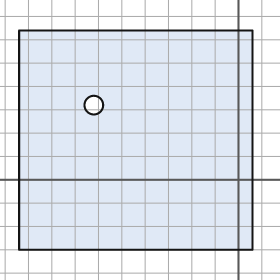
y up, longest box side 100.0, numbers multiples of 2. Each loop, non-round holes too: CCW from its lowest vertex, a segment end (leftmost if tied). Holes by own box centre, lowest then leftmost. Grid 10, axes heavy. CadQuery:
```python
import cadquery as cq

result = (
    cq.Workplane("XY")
    .moveTo(-94.0, -30.0)
    .lineTo(6.0, -30.0)
    .lineTo(6.0, 64.0)
    .lineTo(-94.0, 64.0)
    .close()
    .moveTo(-62.0, 32.0)
    .circle(4.0)
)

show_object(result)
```